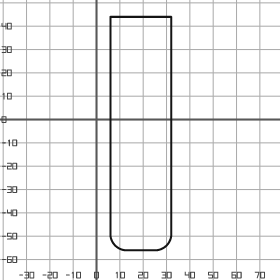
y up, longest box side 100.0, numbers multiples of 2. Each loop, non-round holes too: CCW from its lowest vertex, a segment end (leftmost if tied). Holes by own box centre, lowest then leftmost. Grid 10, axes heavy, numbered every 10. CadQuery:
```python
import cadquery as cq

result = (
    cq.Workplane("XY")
    .moveTo(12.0, -56.0)
    .lineTo(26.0, -56.0)
    .threePointArc((30.0, -54.0), (32.0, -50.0))
    .lineTo(32.0, 44.0)
    .lineTo(6.0, 44.0)
    .lineTo(6.0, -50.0)
    .threePointArc((8.0, -54.0), (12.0, -56.0))
    .close()
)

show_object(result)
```